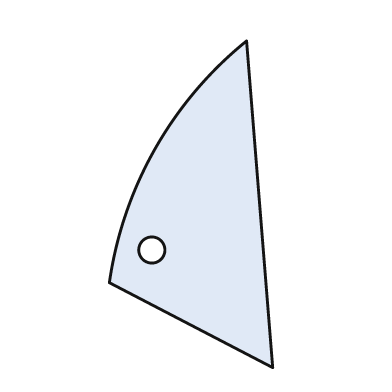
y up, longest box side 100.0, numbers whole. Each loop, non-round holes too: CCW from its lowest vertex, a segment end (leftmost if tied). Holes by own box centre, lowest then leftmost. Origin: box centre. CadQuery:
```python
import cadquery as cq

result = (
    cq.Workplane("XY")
    .moveTo(25.0, -50.0)
    .lineTo(17.0, 50.0)
    .threePointArc((-11.0, 17.0), (-25.0, -24.0))
    .close()
    .moveTo(-12.0, -14.0)
    .circle(4.0)
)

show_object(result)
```